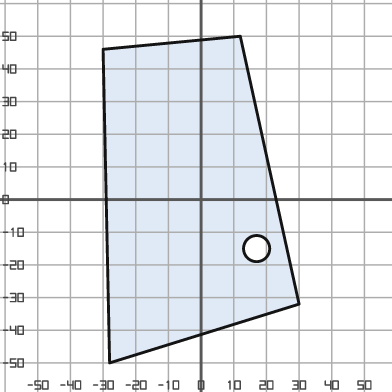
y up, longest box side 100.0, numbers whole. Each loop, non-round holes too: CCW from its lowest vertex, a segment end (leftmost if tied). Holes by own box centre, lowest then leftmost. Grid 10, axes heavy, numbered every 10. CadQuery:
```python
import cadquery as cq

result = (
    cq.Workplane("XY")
    .moveTo(-28.0, -50.0)
    .lineTo(30.0, -32.0)
    .lineTo(12.0, 50.0)
    .lineTo(-30.0, 46.0)
    .close()
    .moveTo(17.0, -15.0)
    .circle(4.0)
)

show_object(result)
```